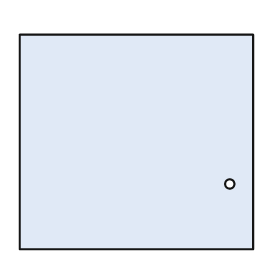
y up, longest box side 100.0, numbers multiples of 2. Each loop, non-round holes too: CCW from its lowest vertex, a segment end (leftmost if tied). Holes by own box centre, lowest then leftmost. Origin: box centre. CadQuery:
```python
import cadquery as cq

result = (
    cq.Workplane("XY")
    .moveTo(-50.0, -46.0)
    .lineTo(50.0, -46.0)
    .lineTo(50.0, 46.0)
    .lineTo(-50.0, 46.0)
    .close()
    .moveTo(40.0, -18.0)
    .circle(2.0)
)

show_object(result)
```